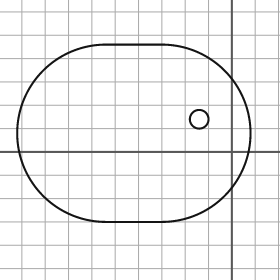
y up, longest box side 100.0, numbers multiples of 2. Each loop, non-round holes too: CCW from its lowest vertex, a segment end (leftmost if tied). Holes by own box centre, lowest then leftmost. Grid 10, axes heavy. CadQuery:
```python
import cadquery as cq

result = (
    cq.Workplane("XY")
    .moveTo(-54.0, -30.0)
    .lineTo(-30.0, -30.0)
    .threePointArc((8.0, 8.0), (-30.0, 46.0))
    .lineTo(-54.0, 46.0)
    .threePointArc((-92.0, 8.0), (-54.0, -30.0))
    .close()
    .moveTo(-14.0, 14.0)
    .circle(4.0)
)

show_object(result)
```